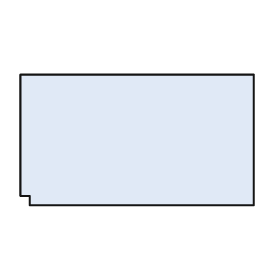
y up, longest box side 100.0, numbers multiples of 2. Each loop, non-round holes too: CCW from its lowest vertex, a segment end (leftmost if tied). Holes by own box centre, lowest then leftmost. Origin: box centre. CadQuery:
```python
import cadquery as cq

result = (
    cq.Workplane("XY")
    .moveTo(-46.0, -28.0)
    .lineTo(50.0, -28.0)
    .lineTo(50.0, 28.0)
    .lineTo(-50.0, 28.0)
    .lineTo(-50.0, -24.0)
    .lineTo(-46.0, -24.0)
    .close()
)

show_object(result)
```